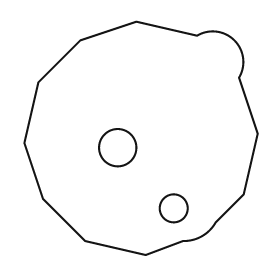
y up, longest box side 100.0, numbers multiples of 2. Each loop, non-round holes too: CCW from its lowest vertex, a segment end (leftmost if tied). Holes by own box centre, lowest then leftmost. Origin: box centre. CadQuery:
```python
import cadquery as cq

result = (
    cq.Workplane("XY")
    .moveTo(2.0, -50.0)
    .lineTo(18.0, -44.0)
    .threePointArc((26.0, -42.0), (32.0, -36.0))
    .lineTo(44.0, -24.0)
    .lineTo(50.0, 2.0)
    .lineTo(42.0, 26.0)
    .threePointArc((40.0, 42.0), (24.0, 44.0))
    .lineTo(-2.0, 50.0)
    .lineTo(-26.0, 42.0)
    .lineTo(-44.0, 24.0)
    .lineTo(-50.0, -2.0)
    .lineTo(-42.0, -26.0)
    .lineTo(-24.0, -44.0)
    .close()
    .moveTo(14.0, -30.0)
    .circle(6.0)
    .moveTo(-10.0, -4.0)
    .circle(8.0)
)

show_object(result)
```